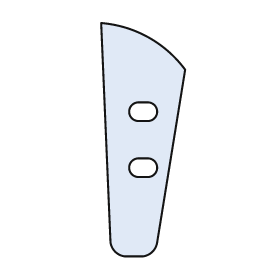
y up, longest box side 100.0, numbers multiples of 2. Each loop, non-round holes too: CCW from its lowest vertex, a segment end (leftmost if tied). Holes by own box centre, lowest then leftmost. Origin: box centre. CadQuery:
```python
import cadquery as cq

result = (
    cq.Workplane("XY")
    .moveTo(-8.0, -50.0)
    .lineTo(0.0, -50.0)
    .threePointArc((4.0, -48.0), (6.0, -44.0))
    .lineTo(18.0, 30.0)
    .threePointArc((2.0, 44.0), (-18.0, 50.0))
    .lineTo(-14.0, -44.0)
    .threePointArc((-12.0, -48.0), (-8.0, -50.0))
    .close()
    .moveTo(-2.0, -16.0)
    .lineTo(2.0, -16.0)
    .threePointArc((6.0, -12.0), (2.0, -8.0))
    .lineTo(-2.0, -8.0)
    .threePointArc((-6.0, -12.0), (-2.0, -16.0))
    .close()
    .moveTo(-2.0, 8.0)
    .lineTo(2.0, 8.0)
    .threePointArc((6.0, 12.0), (2.0, 16.0))
    .lineTo(-2.0, 16.0)
    .threePointArc((-6.0, 12.0), (-2.0, 8.0))
    .close()
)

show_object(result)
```